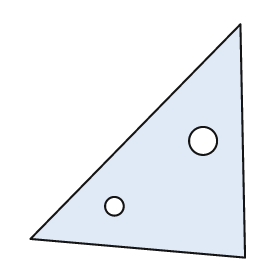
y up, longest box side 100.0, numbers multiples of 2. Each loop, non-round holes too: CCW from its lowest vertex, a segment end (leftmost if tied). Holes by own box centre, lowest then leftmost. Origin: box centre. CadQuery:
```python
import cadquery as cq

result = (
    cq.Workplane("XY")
    .moveTo(46.0, -50.0)
    .lineTo(44.0, 50.0)
    .lineTo(-46.0, -42.0)
    .close()
    .moveTo(-10.0, -28.0)
    .circle(4.0)
    .moveTo(28.0, 0.0)
    .circle(6.0)
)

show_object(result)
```